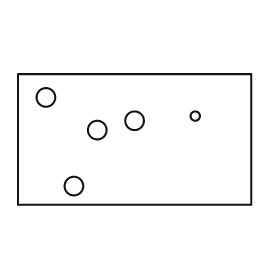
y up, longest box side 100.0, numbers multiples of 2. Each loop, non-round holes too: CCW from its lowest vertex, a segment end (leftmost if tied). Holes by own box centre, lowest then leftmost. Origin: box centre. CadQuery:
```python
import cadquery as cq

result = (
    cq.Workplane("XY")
    .moveTo(-50.0, -28.0)
    .lineTo(50.0, -28.0)
    .lineTo(50.0, 28.0)
    .lineTo(-50.0, 28.0)
    .close()
    .moveTo(-26.0, -20.0)
    .circle(4.0)
    .moveTo(-16.0, 4.0)
    .circle(4.0)
    .moveTo(0.0, 8.0)
    .circle(4.0)
    .moveTo(26.0, 10.0)
    .circle(2.0)
    .moveTo(-38.0, 18.0)
    .circle(4.0)
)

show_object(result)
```